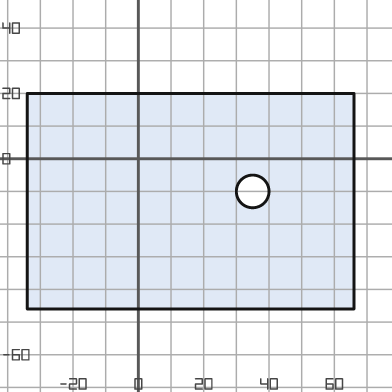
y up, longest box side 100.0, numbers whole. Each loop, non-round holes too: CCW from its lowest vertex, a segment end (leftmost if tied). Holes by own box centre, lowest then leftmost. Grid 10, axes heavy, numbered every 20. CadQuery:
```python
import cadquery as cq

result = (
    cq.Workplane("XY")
    .moveTo(-34.0, -46.0)
    .lineTo(66.0, -46.0)
    .lineTo(66.0, 20.0)
    .lineTo(-34.0, 20.0)
    .close()
    .moveTo(35.0, -10.0)
    .circle(5.0)
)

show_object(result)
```